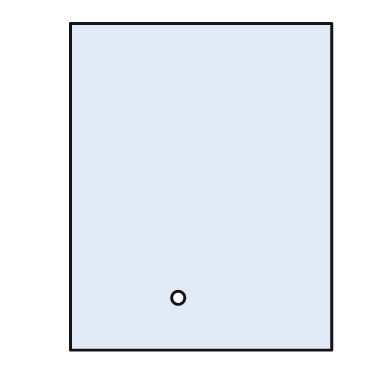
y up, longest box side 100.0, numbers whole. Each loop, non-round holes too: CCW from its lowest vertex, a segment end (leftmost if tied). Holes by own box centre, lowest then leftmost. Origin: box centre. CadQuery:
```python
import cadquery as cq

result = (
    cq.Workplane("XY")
    .moveTo(-40.0, -50.0)
    .lineTo(40.0, -50.0)
    .lineTo(40.0, 50.0)
    .lineTo(-40.0, 50.0)
    .close()
    .moveTo(-7.0, -34.0)
    .circle(2.0)
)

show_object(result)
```